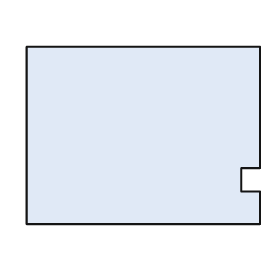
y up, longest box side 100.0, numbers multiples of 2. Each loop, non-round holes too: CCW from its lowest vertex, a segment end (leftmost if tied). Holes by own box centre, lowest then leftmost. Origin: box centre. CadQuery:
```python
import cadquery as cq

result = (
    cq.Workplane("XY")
    .moveTo(-50.0, -38.0)
    .lineTo(50.0, -38.0)
    .lineTo(50.0, -24.0)
    .lineTo(42.0, -24.0)
    .lineTo(42.0, -14.0)
    .lineTo(50.0, -14.0)
    .lineTo(50.0, 38.0)
    .lineTo(-50.0, 38.0)
    .close()
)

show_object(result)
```